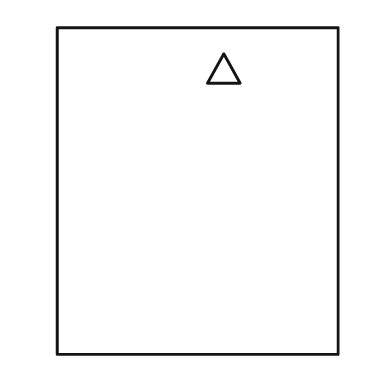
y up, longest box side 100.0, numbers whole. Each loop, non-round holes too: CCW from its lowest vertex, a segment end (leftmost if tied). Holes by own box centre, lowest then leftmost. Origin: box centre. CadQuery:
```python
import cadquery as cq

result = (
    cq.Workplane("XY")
    .moveTo(-43.0, -50.0)
    .lineTo(43.0, -50.0)
    .lineTo(43.0, 50.0)
    .lineTo(-43.0, 50.0)
    .close()
    .moveTo(3.0, 33.0)
    .lineTo(13.0, 33.0)
    .lineTo(8.0, 42.0)
    .close()
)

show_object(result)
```